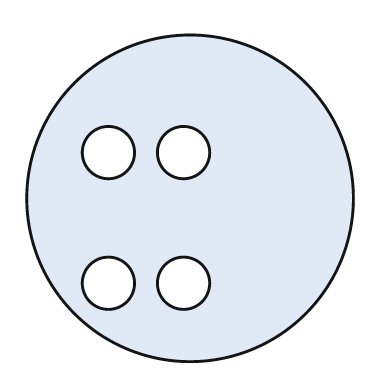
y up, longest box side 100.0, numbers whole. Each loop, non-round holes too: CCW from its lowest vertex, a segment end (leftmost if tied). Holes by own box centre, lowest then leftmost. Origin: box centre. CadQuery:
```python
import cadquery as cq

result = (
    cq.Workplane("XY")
    .moveTo(0.0, 0.0)
    .circle(50.0)
    .moveTo(-25.0, -26.0)
    .circle(8.0)
    .moveTo(-2.0, -26.0)
    .circle(8.0)
    .moveTo(-25.0, 14.0)
    .circle(8.0)
    .moveTo(-2.0, 14.0)
    .circle(8.0)
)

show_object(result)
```